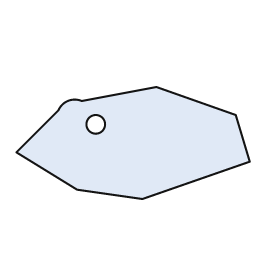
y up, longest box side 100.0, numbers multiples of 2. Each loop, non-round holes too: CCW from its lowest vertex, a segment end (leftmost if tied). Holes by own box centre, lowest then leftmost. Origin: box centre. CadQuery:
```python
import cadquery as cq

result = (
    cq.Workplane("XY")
    .moveTo(4.0, -24.0)
    .lineTo(50.0, -8.0)
    .lineTo(44.0, 12.0)
    .lineTo(10.0, 24.0)
    .lineTo(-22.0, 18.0)
    .threePointArc((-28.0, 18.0), (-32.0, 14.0))
    .lineTo(-50.0, -4.0)
    .lineTo(-24.0, -20.0)
    .close()
    .moveTo(-16.0, 8.0)
    .circle(4.0)
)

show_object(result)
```